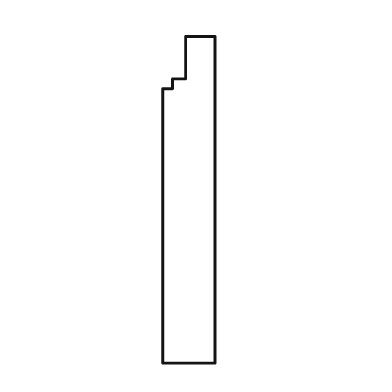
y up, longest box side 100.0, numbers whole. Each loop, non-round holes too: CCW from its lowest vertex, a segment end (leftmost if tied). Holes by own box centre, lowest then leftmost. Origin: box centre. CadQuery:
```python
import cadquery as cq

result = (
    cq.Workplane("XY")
    .moveTo(-8.0, -50.0)
    .lineTo(8.0, -50.0)
    .lineTo(8.0, 50.0)
    .lineTo(-1.0, 50.0)
    .lineTo(-1.0, 37.0)
    .lineTo(-5.0, 37.0)
    .lineTo(-5.0, 34.0)
    .lineTo(-8.0, 34.0)
    .close()
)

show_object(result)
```